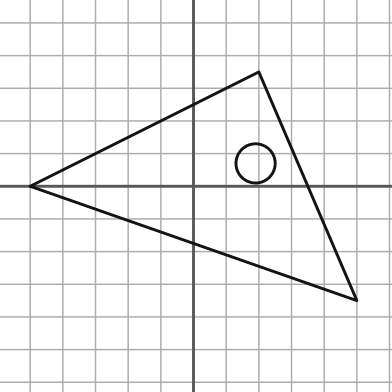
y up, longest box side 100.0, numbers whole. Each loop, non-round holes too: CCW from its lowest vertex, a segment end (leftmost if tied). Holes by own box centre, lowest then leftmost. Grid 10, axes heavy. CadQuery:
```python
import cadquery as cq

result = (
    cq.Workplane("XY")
    .moveTo(50.0, -35.0)
    .lineTo(20.0, 35.0)
    .lineTo(-50.0, 0.0)
    .close()
    .moveTo(19.0, 7.0)
    .circle(6.0)
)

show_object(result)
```